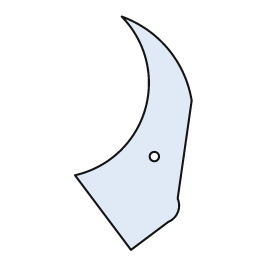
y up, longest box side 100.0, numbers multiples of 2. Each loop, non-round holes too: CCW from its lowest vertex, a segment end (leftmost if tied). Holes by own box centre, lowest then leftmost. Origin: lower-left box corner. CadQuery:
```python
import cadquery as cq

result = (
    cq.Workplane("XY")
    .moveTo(24.0, 0.0)
    .lineTo(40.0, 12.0)
    .threePointArc((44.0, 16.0), (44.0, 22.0))
    .lineTo(50.0, 64.0)
    .threePointArc((40.0, 86.0), (20.0, 100.0))
    .threePointArc((30.0, 60.0), (0.0, 32.0))
    .close()
    .moveTo(34.0, 40.0)
    .circle(2.0)
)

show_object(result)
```